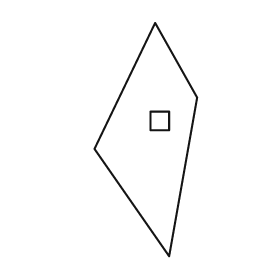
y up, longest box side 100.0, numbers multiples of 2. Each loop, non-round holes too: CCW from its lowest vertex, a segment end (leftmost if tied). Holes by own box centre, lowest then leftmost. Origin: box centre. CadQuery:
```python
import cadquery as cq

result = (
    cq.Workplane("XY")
    .moveTo(10.0, -50.0)
    .lineTo(22.0, 18.0)
    .lineTo(4.0, 50.0)
    .lineTo(-22.0, -4.0)
    .close()
    .moveTo(2.0, 4.0)
    .lineTo(10.0, 4.0)
    .lineTo(10.0, 12.0)
    .lineTo(2.0, 12.0)
    .close()
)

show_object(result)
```